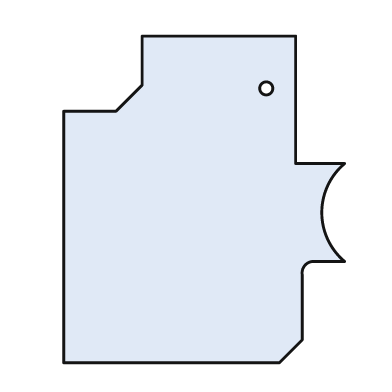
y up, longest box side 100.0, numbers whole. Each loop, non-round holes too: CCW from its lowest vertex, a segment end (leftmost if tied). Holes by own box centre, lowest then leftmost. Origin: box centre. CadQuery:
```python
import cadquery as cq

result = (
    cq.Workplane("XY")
    .moveTo(-43.0, -50.0)
    .lineTo(23.0, -50.0)
    .lineTo(30.0, -43.0)
    .lineTo(30.0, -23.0)
    .threePointArc((31.0, -20.0), (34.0, -19.0))
    .lineTo(43.0, -19.0)
    .threePointArc((36.0, -4.0), (43.0, 11.0))
    .lineTo(28.0, 11.0)
    .lineTo(28.0, 50.0)
    .lineTo(-19.0, 50.0)
    .lineTo(-19.0, 35.0)
    .lineTo(-27.0, 27.0)
    .lineTo(-43.0, 27.0)
    .close()
    .moveTo(19.0, 34.0)
    .circle(2.0)
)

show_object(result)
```